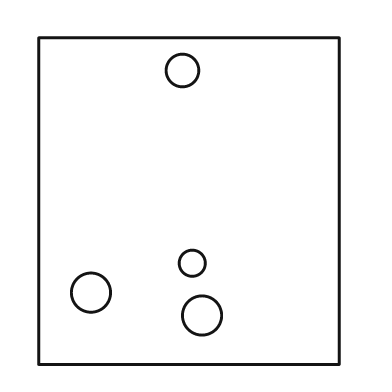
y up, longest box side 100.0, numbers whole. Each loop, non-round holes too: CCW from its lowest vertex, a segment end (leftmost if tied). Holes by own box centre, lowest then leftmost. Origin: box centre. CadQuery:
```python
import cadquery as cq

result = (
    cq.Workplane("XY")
    .moveTo(-46.0, -50.0)
    .lineTo(46.0, -50.0)
    .lineTo(46.0, 50.0)
    .lineTo(-46.0, 50.0)
    .close()
    .moveTo(4.0, -35.0)
    .circle(6.0)
    .moveTo(-30.0, -28.0)
    .circle(6.0)
    .moveTo(1.0, -19.0)
    .circle(4.0)
    .moveTo(-2.0, 40.0)
    .circle(5.0)
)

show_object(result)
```